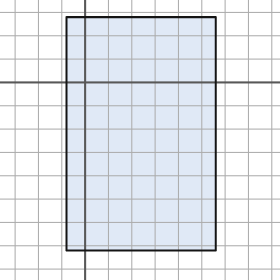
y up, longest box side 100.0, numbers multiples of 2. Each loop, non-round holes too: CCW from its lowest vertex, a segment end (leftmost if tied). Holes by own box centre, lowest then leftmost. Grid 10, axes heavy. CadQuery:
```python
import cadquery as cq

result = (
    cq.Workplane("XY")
    .moveTo(-8.0, -72.0)
    .lineTo(56.0, -72.0)
    .lineTo(56.0, 28.0)
    .lineTo(-8.0, 28.0)
    .close()
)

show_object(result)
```